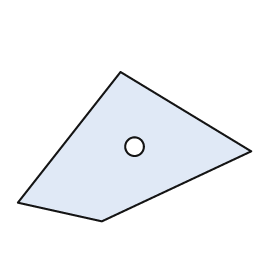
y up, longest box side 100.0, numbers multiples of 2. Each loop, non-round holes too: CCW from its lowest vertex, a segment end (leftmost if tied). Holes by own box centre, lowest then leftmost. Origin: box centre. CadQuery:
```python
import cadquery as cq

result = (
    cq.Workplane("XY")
    .moveTo(-14.0, -32.0)
    .lineTo(50.0, -2.0)
    .lineTo(-6.0, 32.0)
    .lineTo(-50.0, -24.0)
    .close()
    .moveTo(0.0, 0.0)
    .circle(4.0)
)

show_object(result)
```